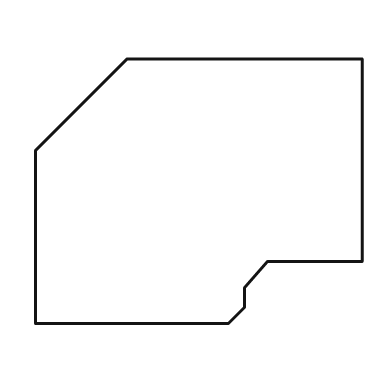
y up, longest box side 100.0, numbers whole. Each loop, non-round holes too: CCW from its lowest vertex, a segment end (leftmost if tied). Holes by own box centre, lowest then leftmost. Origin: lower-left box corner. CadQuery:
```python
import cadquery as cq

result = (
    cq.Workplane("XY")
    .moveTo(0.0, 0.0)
    .lineTo(59.0, 0.0)
    .lineTo(64.0, 5.0)
    .lineTo(64.0, 11.0)
    .lineTo(71.0, 19.0)
    .lineTo(100.0, 19.0)
    .lineTo(100.0, 81.0)
    .lineTo(28.0, 81.0)
    .lineTo(0.0, 53.0)
    .close()
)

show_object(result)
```